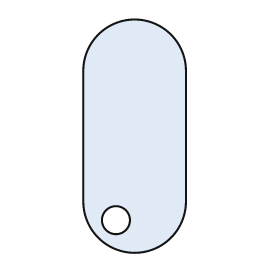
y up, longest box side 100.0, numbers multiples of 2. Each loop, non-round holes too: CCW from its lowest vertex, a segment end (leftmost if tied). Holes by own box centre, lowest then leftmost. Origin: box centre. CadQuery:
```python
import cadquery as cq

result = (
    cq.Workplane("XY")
    .moveTo(-22.0, -28.0)
    .threePointArc((0.0, -50.0), (22.0, -28.0))
    .lineTo(22.0, 28.0)
    .threePointArc((0.0, 50.0), (-22.0, 28.0))
    .close()
    .moveTo(-8.0, -36.0)
    .circle(6.0)
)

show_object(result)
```